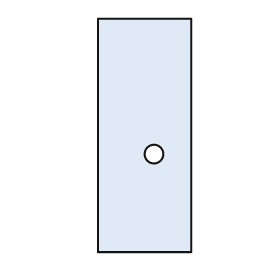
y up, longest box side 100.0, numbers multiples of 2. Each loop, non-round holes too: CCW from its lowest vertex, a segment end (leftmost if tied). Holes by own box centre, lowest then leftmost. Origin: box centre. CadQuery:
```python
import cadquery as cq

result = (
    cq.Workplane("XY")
    .moveTo(-20.0, -50.0)
    .lineTo(20.0, -50.0)
    .lineTo(20.0, 50.0)
    .lineTo(-20.0, 50.0)
    .close()
    .moveTo(4.0, -8.0)
    .circle(4.0)
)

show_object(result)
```